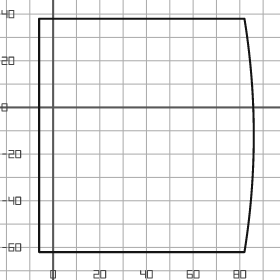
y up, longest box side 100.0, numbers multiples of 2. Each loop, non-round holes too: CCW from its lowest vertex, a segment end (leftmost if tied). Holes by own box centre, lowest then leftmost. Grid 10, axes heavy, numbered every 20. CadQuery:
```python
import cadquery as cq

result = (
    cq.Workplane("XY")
    .moveTo(-6.0, -62.0)
    .lineTo(82.0, -62.0)
    .threePointArc((86.0, -12.0), (82.0, 38.0))
    .lineTo(-6.0, 38.0)
    .close()
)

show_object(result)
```